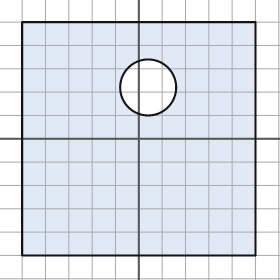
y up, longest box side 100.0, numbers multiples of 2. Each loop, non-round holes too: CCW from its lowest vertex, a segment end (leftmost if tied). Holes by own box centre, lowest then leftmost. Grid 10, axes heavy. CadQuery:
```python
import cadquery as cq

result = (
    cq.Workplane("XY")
    .moveTo(-50.0, -50.0)
    .lineTo(50.0, -50.0)
    .lineTo(50.0, 50.0)
    .lineTo(-50.0, 50.0)
    .close()
    .moveTo(4.0, 22.0)
    .circle(12.0)
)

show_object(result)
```